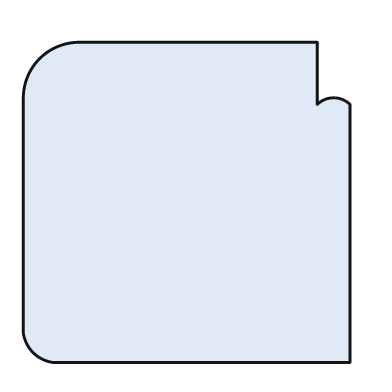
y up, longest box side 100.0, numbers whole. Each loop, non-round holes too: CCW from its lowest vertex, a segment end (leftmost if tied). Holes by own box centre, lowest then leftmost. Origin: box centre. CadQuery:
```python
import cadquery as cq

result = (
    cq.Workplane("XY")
    .moveTo(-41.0, -49.0)
    .lineTo(50.0, -49.0)
    .lineTo(50.0, 30.0)
    .threePointArc((45.0, 32.0), (40.0, 30.0))
    .lineTo(40.0, 49.0)
    .lineTo(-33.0, 49.0)
    .threePointArc((-45.0, 44.0), (-50.0, 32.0))
    .lineTo(-50.0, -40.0)
    .threePointArc((-47.0, -46.0), (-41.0, -49.0))
    .close()
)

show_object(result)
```